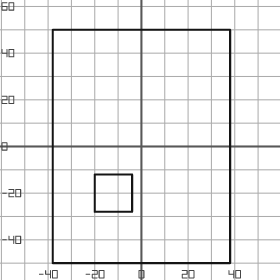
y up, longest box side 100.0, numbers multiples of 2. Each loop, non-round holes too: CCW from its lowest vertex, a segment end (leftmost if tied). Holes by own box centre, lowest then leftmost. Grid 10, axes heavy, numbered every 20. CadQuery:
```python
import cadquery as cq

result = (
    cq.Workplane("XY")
    .moveTo(-38.0, -50.0)
    .lineTo(38.0, -50.0)
    .lineTo(38.0, 50.0)
    .lineTo(-38.0, 50.0)
    .close()
    .moveTo(-20.0, -28.0)
    .lineTo(-4.0, -28.0)
    .lineTo(-4.0, -12.0)
    .lineTo(-20.0, -12.0)
    .close()
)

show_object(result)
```